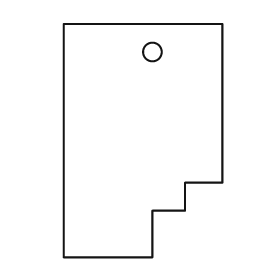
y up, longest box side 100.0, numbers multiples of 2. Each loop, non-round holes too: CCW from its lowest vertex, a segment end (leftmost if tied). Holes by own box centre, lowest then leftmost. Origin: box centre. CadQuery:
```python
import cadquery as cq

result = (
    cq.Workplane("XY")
    .moveTo(-34.0, -50.0)
    .lineTo(4.0, -50.0)
    .lineTo(4.0, -30.0)
    .lineTo(18.0, -30.0)
    .lineTo(18.0, -18.0)
    .lineTo(34.0, -18.0)
    .lineTo(34.0, 50.0)
    .lineTo(-34.0, 50.0)
    .close()
    .moveTo(4.0, 38.0)
    .circle(4.0)
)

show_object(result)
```